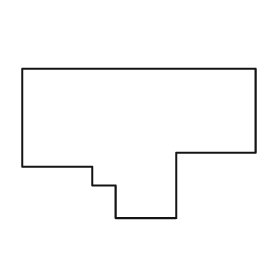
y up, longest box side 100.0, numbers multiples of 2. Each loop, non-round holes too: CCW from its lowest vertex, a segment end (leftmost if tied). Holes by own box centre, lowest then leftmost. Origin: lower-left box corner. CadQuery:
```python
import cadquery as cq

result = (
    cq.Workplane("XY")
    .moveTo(40.0, 0.0)
    .lineTo(66.0, 0.0)
    .lineTo(66.0, 28.0)
    .lineTo(100.0, 28.0)
    .lineTo(100.0, 64.0)
    .lineTo(0.0, 64.0)
    .lineTo(0.0, 22.0)
    .lineTo(30.0, 22.0)
    .lineTo(30.0, 14.0)
    .lineTo(40.0, 14.0)
    .close()
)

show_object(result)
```